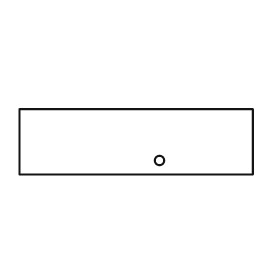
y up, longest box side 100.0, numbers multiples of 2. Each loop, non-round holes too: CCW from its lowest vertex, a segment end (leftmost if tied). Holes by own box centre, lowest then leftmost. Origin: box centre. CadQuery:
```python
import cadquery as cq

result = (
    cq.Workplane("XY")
    .moveTo(-50.0, -14.0)
    .lineTo(50.0, -14.0)
    .lineTo(50.0, 14.0)
    .lineTo(-50.0, 14.0)
    .close()
    .moveTo(10.0, -8.0)
    .circle(2.0)
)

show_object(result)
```